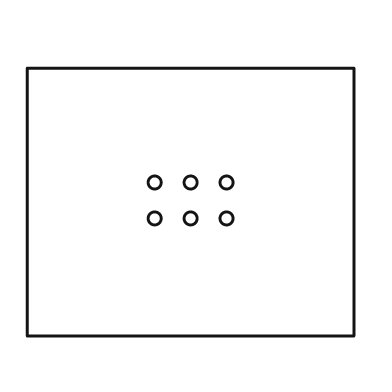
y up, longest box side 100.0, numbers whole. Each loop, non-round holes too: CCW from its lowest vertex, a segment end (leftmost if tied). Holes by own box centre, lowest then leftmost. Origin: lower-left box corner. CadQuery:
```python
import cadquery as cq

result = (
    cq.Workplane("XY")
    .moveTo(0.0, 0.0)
    .lineTo(100.0, 0.0)
    .lineTo(100.0, 82.0)
    .lineTo(0.0, 82.0)
    .close()
    .moveTo(39.0, 36.0)
    .circle(2.0)
    .moveTo(50.0, 36.0)
    .circle(2.0)
    .moveTo(61.0, 36.0)
    .circle(2.0)
    .moveTo(39.0, 47.0)
    .circle(2.0)
    .moveTo(50.0, 47.0)
    .circle(2.0)
    .moveTo(61.0, 47.0)
    .circle(2.0)
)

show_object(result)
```